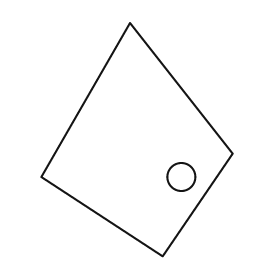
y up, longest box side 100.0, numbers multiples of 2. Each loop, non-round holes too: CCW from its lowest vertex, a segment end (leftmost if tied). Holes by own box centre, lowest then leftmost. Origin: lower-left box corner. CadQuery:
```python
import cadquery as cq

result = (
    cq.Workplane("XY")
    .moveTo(52.0, 0.0)
    .lineTo(82.0, 44.0)
    .lineTo(38.0, 100.0)
    .lineTo(0.0, 34.0)
    .close()
    .moveTo(60.0, 34.0)
    .circle(6.0)
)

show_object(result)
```